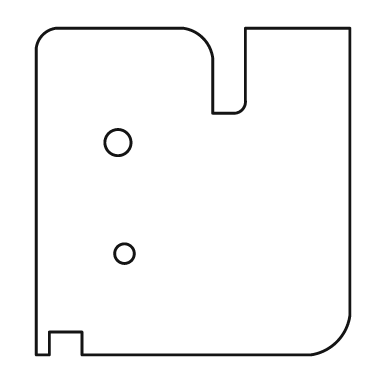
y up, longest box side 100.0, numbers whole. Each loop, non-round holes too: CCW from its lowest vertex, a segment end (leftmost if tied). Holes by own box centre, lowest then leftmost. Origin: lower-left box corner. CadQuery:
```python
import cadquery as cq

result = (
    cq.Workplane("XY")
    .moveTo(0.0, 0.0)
    .lineTo(4.0, 0.0)
    .lineTo(4.0, 7.0)
    .lineTo(14.0, 7.0)
    .lineTo(14.0, 0.0)
    .lineTo(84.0, 0.0)
    .threePointArc((92.0, 4.0), (96.0, 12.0))
    .lineTo(96.0, 100.0)
    .lineTo(64.0, 100.0)
    .lineTo(64.0, 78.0)
    .threePointArc((63.0, 75.0), (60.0, 74.0))
    .lineTo(54.0, 74.0)
    .lineTo(54.0, 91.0)
    .threePointArc((51.0, 97.0), (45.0, 100.0))
    .lineTo(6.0, 100.0)
    .threePointArc((2.0, 98.0), (0.0, 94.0))
    .close()
    .moveTo(27.0, 31.0)
    .circle(3.0)
    .moveTo(25.0, 65.0)
    .circle(4.0)
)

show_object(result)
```